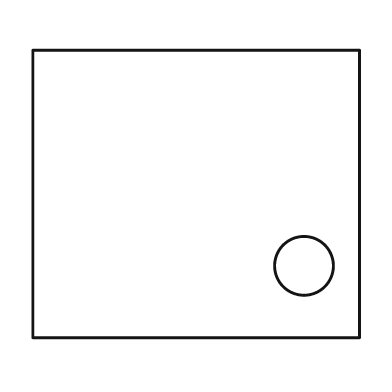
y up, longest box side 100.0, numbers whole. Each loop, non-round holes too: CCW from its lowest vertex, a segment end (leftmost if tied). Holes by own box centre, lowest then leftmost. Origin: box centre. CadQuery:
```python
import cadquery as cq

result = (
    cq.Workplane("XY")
    .moveTo(-50.0, -44.0)
    .lineTo(50.0, -44.0)
    .lineTo(50.0, 44.0)
    .lineTo(-50.0, 44.0)
    .close()
    .moveTo(33.0, -22.0)
    .circle(9.0)
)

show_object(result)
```